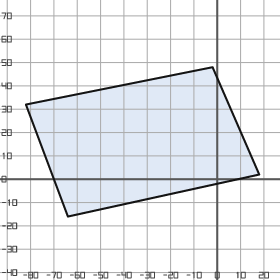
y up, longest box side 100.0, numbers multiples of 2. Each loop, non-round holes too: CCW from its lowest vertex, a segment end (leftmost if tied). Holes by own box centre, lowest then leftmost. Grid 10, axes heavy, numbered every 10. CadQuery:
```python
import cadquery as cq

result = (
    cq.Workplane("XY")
    .moveTo(-64.0, -16.0)
    .lineTo(18.0, 2.0)
    .lineTo(-2.0, 48.0)
    .lineTo(-82.0, 32.0)
    .close()
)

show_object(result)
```